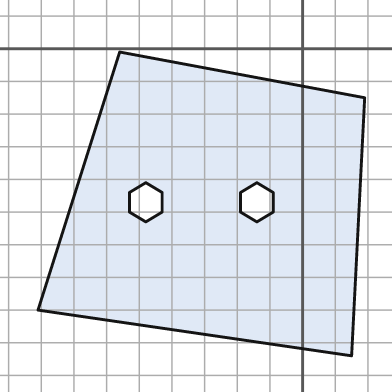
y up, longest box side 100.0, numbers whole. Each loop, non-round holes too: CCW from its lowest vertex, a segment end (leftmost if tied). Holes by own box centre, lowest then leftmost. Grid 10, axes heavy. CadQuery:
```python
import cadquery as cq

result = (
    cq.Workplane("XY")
    .moveTo(15.0, -94.0)
    .lineTo(19.0, -15.0)
    .lineTo(-56.0, -1.0)
    .lineTo(-81.0, -80.0)
    .close()
    .moveTo(-48.0, -53.0)
    .lineTo(-43.0, -50.0)
    .lineTo(-43.0, -44.0)
    .lineTo(-48.0, -41.0)
    .lineTo(-53.0, -44.0)
    .lineTo(-53.0, -50.0)
    .close()
    .moveTo(-14.0, -53.0)
    .lineTo(-9.0, -50.0)
    .lineTo(-9.0, -44.0)
    .lineTo(-14.0, -41.0)
    .lineTo(-19.0, -44.0)
    .lineTo(-19.0, -50.0)
    .close()
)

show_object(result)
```